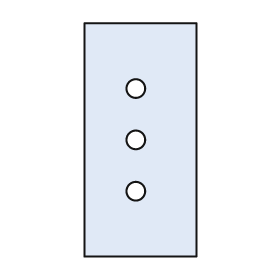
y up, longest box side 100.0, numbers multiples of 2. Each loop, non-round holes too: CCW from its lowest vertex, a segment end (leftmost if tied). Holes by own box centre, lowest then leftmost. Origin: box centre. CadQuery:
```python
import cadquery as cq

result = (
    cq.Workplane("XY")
    .moveTo(-24.0, -50.0)
    .lineTo(24.0, -50.0)
    .lineTo(24.0, 50.0)
    .lineTo(-24.0, 50.0)
    .close()
    .moveTo(-2.0, -22.0)
    .circle(4.0)
    .moveTo(-2.0, 0.0)
    .circle(4.0)
    .moveTo(-2.0, 22.0)
    .circle(4.0)
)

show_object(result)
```